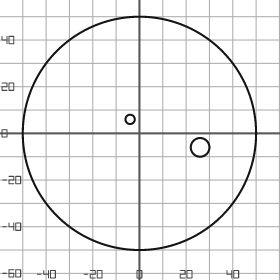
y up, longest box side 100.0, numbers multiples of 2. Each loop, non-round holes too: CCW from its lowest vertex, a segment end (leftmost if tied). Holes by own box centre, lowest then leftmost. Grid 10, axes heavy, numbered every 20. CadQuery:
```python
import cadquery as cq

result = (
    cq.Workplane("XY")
    .moveTo(0.0, 0.0)
    .circle(50.0)
    .moveTo(26.0, -6.0)
    .circle(4.0)
    .moveTo(-4.0, 6.0)
    .circle(2.0)
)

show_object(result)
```